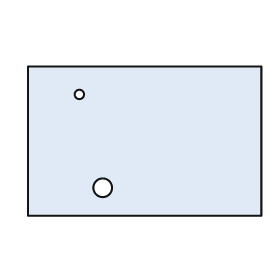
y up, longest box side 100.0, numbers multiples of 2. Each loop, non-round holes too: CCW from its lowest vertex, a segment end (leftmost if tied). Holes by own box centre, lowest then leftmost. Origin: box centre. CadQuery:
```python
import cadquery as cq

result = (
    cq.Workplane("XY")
    .moveTo(-50.0, -32.0)
    .lineTo(50.0, -32.0)
    .lineTo(50.0, 32.0)
    .lineTo(-50.0, 32.0)
    .close()
    .moveTo(-18.0, -20.0)
    .circle(4.0)
    .moveTo(-28.0, 20.0)
    .circle(2.0)
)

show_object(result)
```